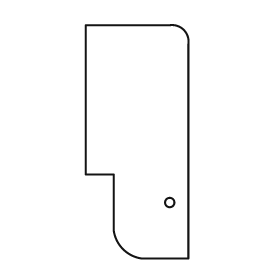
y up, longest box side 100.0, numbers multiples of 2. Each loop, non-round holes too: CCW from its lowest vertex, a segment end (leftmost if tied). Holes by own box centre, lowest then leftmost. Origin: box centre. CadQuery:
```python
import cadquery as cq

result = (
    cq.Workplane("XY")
    .moveTo(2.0, -50.0)
    .lineTo(22.0, -50.0)
    .lineTo(22.0, 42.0)
    .threePointArc((20.0, 48.0), (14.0, 50.0))
    .lineTo(-22.0, 50.0)
    .lineTo(-22.0, -14.0)
    .lineTo(-10.0, -14.0)
    .lineTo(-10.0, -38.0)
    .threePointArc((-6.0, -46.0), (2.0, -50.0))
    .close()
    .moveTo(14.0, -26.0)
    .circle(2.0)
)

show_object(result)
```